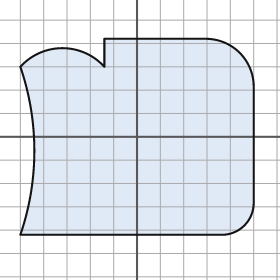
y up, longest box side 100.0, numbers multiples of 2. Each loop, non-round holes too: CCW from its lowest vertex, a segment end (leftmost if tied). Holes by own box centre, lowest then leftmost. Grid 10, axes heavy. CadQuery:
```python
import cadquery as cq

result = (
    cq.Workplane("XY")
    .moveTo(-50.0, -42.0)
    .lineTo(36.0, -42.0)
    .threePointArc((46.0, -38.0), (50.0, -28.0))
    .lineTo(50.0, 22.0)
    .threePointArc((44.0, 36.0), (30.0, 42.0))
    .lineTo(-14.0, 42.0)
    .lineTo(-14.0, 30.0)
    .threePointArc((-32.0, 38.0), (-50.0, 30.0))
    .threePointArc((-44.0, -6.0), (-50.0, -42.0))
    .close()
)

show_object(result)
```